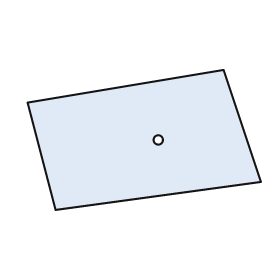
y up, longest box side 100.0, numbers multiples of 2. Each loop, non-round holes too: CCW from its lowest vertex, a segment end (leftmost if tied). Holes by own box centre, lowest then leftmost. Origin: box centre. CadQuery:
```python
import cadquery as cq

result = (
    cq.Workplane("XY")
    .moveTo(-38.0, -30.0)
    .lineTo(50.0, -18.0)
    .lineTo(34.0, 30.0)
    .lineTo(-50.0, 16.0)
    .close()
    .moveTo(6.0, 0.0)
    .circle(2.0)
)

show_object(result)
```